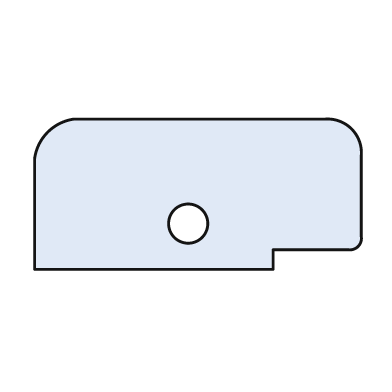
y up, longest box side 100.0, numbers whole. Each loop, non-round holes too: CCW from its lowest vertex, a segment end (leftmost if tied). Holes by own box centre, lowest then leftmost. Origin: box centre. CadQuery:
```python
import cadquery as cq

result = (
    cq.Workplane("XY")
    .moveTo(-50.0, -23.0)
    .lineTo(23.0, -23.0)
    .lineTo(23.0, -17.0)
    .lineTo(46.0, -17.0)
    .threePointArc((49.0, -16.0), (50.0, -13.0))
    .lineTo(50.0, 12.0)
    .threePointArc((47.0, 20.0), (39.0, 23.0))
    .lineTo(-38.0, 23.0)
    .threePointArc((-46.0, 19.0), (-50.0, 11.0))
    .close()
    .moveTo(-3.0, -9.0)
    .circle(6.0)
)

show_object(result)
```